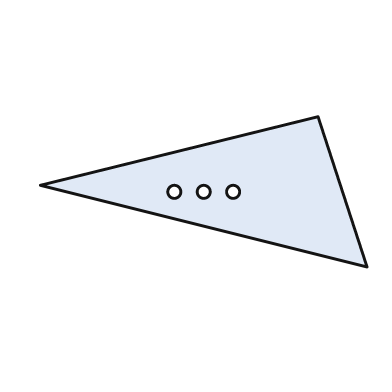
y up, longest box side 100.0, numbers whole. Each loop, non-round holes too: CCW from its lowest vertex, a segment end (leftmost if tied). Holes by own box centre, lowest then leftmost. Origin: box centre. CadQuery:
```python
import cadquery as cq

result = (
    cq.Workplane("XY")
    .moveTo(50.0, -23.0)
    .lineTo(35.0, 23.0)
    .lineTo(-50.0, 2.0)
    .close()
    .moveTo(-9.0, 0.0)
    .circle(2.0)
    .moveTo(0.0, 0.0)
    .circle(2.0)
    .moveTo(9.0, 0.0)
    .circle(2.0)
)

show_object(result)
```